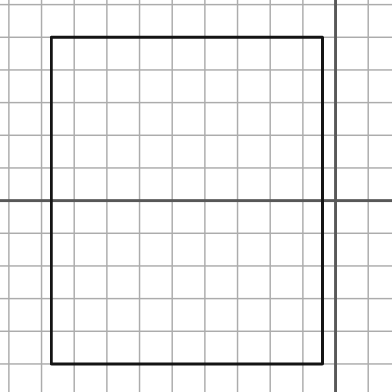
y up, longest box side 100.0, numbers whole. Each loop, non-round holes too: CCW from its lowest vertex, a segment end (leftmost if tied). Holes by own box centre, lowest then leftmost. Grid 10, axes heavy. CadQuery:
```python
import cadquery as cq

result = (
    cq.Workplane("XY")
    .moveTo(-87.0, -50.0)
    .lineTo(-4.0, -50.0)
    .lineTo(-4.0, 50.0)
    .lineTo(-87.0, 50.0)
    .close()
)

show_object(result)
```